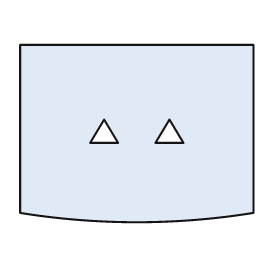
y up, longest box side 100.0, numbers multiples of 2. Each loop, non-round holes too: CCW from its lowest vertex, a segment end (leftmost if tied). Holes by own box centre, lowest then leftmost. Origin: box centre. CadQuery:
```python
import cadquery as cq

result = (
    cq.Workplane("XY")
    .moveTo(-50.0, -34.0)
    .threePointArc((0.0, -38.0), (50.0, -34.0))
    .lineTo(50.0, 38.0)
    .lineTo(-50.0, 38.0)
    .close()
    .moveTo(-20.0, -4.0)
    .lineTo(-8.0, -4.0)
    .lineTo(-14.0, 6.0)
    .close()
    .moveTo(8.0, -4.0)
    .lineTo(20.0, -4.0)
    .lineTo(14.0, 6.0)
    .close()
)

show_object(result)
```